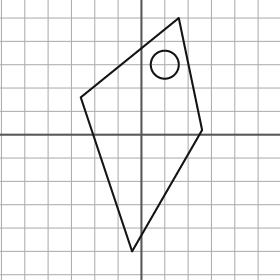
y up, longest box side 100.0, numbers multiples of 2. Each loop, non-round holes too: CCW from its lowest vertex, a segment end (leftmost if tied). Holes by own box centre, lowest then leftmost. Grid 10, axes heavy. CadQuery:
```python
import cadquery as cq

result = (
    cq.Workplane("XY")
    .moveTo(-4.0, -50.0)
    .lineTo(26.0, 2.0)
    .lineTo(16.0, 50.0)
    .lineTo(-26.0, 16.0)
    .close()
    .moveTo(10.0, 30.0)
    .circle(6.0)
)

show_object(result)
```